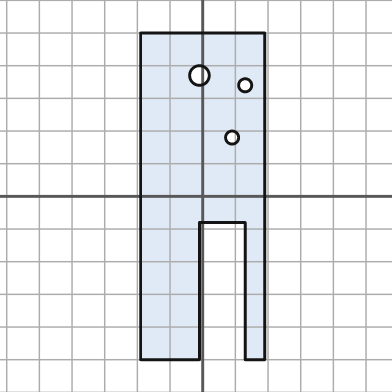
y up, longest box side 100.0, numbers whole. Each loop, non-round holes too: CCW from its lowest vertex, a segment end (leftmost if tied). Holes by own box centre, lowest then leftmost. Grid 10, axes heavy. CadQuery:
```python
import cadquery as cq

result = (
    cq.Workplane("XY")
    .moveTo(-19.0, -50.0)
    .lineTo(-1.0, -50.0)
    .lineTo(-1.0, -8.0)
    .lineTo(13.0, -8.0)
    .lineTo(13.0, -50.0)
    .lineTo(19.0, -50.0)
    .lineTo(19.0, 50.0)
    .lineTo(-19.0, 50.0)
    .close()
    .moveTo(9.0, 18.0)
    .circle(2.0)
    .moveTo(13.0, 34.0)
    .circle(2.0)
    .moveTo(-1.0, 37.0)
    .circle(3.0)
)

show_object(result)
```